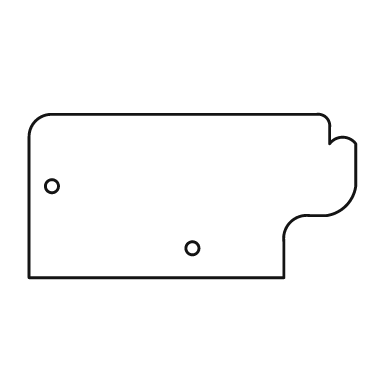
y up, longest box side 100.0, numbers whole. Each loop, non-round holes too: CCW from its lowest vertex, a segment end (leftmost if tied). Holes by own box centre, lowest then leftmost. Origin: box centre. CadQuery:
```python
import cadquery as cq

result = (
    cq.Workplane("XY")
    .moveTo(-50.0, -25.0)
    .lineTo(28.0, -25.0)
    .lineTo(28.0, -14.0)
    .threePointArc((30.0, -8.0), (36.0, -6.0))
    .lineTo(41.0, -6.0)
    .threePointArc((47.0, -3.0), (50.0, 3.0))
    .lineTo(50.0, 16.0)
    .threePointArc((46.0, 18.0), (42.0, 16.0))
    .lineTo(42.0, 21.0)
    .threePointArc((41.0, 24.0), (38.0, 25.0))
    .lineTo(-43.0, 25.0)
    .threePointArc((-48.0, 23.0), (-50.0, 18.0))
    .close()
    .moveTo(0.0, -16.0)
    .circle(2.0)
    .moveTo(-43.0, 3.0)
    .circle(2.0)
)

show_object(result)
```